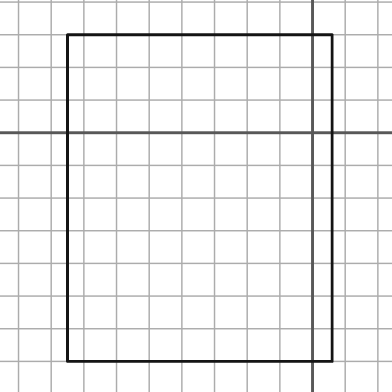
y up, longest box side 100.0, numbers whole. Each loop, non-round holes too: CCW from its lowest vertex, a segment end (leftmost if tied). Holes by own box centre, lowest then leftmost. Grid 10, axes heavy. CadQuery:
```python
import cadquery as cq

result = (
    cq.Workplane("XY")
    .moveTo(-75.0, -70.0)
    .lineTo(6.0, -70.0)
    .lineTo(6.0, 30.0)
    .lineTo(-75.0, 30.0)
    .close()
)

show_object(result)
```